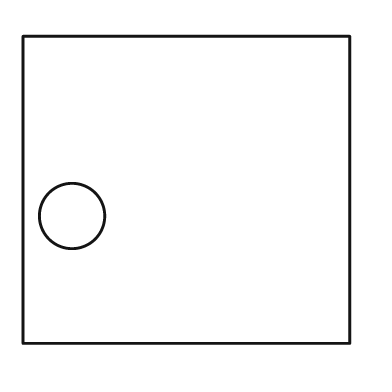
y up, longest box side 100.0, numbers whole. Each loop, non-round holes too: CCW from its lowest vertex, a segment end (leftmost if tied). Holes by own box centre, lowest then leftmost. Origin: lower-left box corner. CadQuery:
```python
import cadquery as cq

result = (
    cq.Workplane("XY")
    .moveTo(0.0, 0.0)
    .lineTo(100.0, 0.0)
    .lineTo(100.0, 94.0)
    .lineTo(0.0, 94.0)
    .close()
    .moveTo(15.0, 39.0)
    .circle(10.0)
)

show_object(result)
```